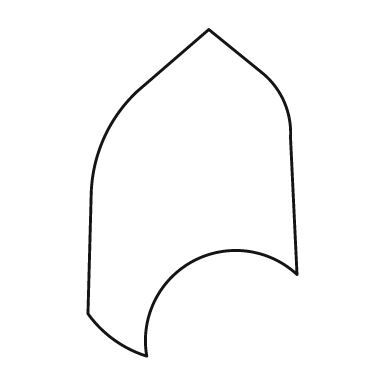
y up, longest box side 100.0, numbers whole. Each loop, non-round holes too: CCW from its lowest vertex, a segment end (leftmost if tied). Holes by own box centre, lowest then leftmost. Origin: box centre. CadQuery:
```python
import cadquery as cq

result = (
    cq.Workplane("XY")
    .moveTo(-14.0, -50.0)
    .threePointArc((0.0, -21.0), (32.0, -25.0))
    .lineTo(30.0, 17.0)
    .threePointArc((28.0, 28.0), (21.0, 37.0))
    .lineTo(5.0, 50.0)
    .lineTo(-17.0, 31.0)
    .threePointArc((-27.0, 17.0), (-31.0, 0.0))
    .lineTo(-32.0, -37.0)
    .threePointArc((-24.0, -45.0), (-14.0, -50.0))
    .close()
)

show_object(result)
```